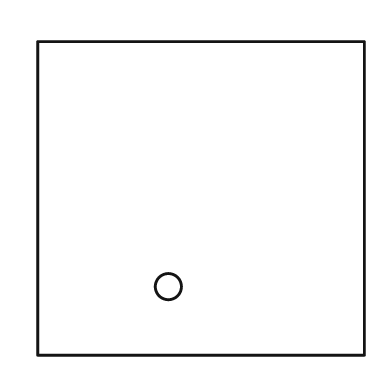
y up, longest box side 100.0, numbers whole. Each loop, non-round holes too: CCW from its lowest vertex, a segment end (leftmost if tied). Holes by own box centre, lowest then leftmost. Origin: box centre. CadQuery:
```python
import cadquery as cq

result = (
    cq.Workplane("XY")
    .moveTo(-50.0, -48.0)
    .lineTo(50.0, -48.0)
    .lineTo(50.0, 48.0)
    .lineTo(-50.0, 48.0)
    .close()
    .moveTo(-10.0, -27.0)
    .circle(4.0)
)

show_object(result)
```